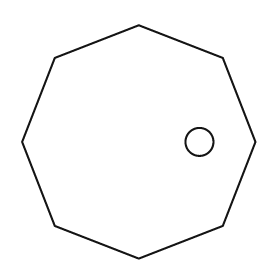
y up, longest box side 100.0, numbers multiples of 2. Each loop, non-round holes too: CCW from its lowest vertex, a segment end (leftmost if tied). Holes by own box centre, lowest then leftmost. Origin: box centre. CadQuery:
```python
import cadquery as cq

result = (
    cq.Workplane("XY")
    .moveTo(0.0, -50.0)
    .lineTo(36.0, -36.0)
    .lineTo(50.0, 0.0)
    .lineTo(36.0, 36.0)
    .lineTo(0.0, 50.0)
    .lineTo(-36.0, 36.0)
    .lineTo(-50.0, 0.0)
    .lineTo(-36.0, -36.0)
    .close()
    .moveTo(26.0, 0.0)
    .circle(6.0)
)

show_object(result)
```